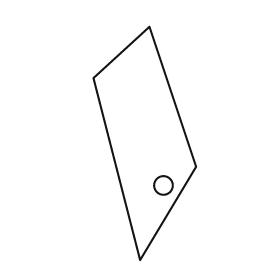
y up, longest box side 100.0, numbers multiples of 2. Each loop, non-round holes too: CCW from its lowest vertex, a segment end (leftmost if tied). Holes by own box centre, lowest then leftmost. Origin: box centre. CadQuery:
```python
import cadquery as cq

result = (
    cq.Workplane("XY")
    .moveTo(-2.0, -50.0)
    .lineTo(22.0, -10.0)
    .lineTo(2.0, 50.0)
    .lineTo(-22.0, 28.0)
    .close()
    .moveTo(8.0, -18.0)
    .circle(4.0)
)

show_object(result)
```